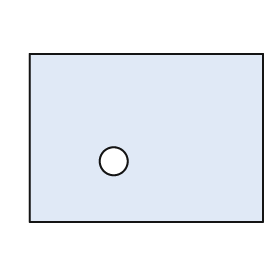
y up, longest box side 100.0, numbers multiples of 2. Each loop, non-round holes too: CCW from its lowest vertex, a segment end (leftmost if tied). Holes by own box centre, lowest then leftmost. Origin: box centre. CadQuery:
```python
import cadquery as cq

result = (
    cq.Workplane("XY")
    .moveTo(-50.0, -36.0)
    .lineTo(50.0, -36.0)
    .lineTo(50.0, 36.0)
    .lineTo(-50.0, 36.0)
    .close()
    .moveTo(-14.0, -10.0)
    .circle(6.0)
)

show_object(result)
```